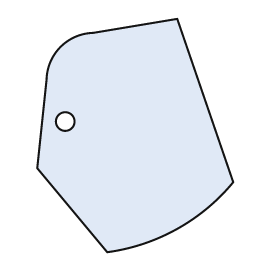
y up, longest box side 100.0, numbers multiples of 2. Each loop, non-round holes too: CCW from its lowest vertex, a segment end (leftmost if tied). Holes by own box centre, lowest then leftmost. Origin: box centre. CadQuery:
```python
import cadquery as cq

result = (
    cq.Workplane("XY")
    .moveTo(-12.0, -50.0)
    .threePointArc((18.0, -40.0), (42.0, -20.0))
    .lineTo(18.0, 50.0)
    .lineTo(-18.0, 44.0)
    .threePointArc((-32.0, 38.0), (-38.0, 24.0))
    .lineTo(-42.0, -14.0)
    .close()
    .moveTo(-30.0, 6.0)
    .circle(4.0)
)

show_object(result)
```